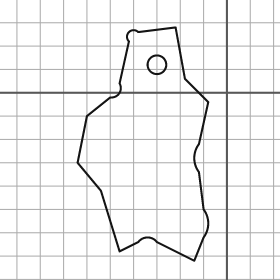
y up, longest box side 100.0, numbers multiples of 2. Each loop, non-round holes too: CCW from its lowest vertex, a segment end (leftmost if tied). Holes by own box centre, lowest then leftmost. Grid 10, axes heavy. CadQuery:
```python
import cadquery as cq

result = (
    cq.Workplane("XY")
    .moveTo(-14.0, -72.0)
    .lineTo(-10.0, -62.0)
    .threePointArc((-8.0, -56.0), (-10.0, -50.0))
    .lineTo(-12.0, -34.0)
    .threePointArc((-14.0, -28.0), (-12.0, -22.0))
    .lineTo(-8.0, -4.0)
    .lineTo(-18.0, 6.0)
    .lineTo(-22.0, 28.0)
    .lineTo(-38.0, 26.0)
    .threePointArc((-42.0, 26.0), (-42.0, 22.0))
    .lineTo(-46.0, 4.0)
    .threePointArc((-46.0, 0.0), (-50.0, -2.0))
    .lineTo(-60.0, -10.0)
    .lineTo(-64.0, -30.0)
    .lineTo(-54.0, -42.0)
    .lineTo(-46.0, -68.0)
    .lineTo(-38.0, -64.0)
    .threePointArc((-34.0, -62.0), (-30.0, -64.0))
    .close()
    .moveTo(-30.0, 12.0)
    .circle(4.0)
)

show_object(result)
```